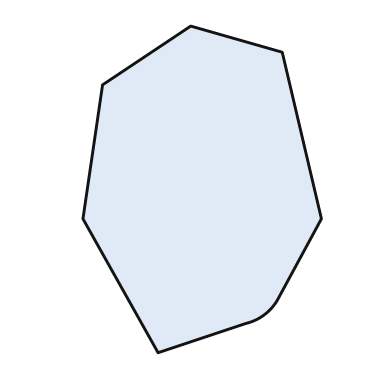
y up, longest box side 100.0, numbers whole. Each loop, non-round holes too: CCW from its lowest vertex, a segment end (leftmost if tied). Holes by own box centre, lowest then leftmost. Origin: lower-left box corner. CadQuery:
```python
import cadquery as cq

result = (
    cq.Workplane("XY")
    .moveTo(23.0, 0.0)
    .lineTo(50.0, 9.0)
    .threePointArc((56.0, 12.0), (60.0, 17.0))
    .lineTo(73.0, 41.0)
    .lineTo(61.0, 92.0)
    .lineTo(33.0, 100.0)
    .lineTo(6.0, 82.0)
    .lineTo(0.0, 41.0)
    .close()
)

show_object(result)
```